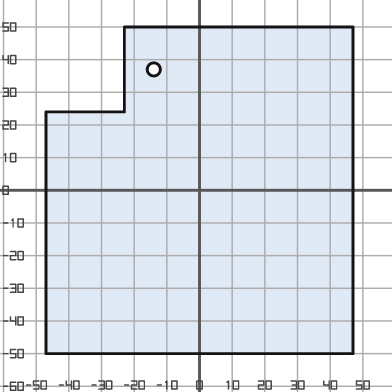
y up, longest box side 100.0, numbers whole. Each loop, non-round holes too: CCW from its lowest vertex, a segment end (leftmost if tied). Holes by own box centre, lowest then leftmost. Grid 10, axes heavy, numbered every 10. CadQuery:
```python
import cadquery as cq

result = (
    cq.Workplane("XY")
    .moveTo(-47.0, -50.0)
    .lineTo(47.0, -50.0)
    .lineTo(47.0, 50.0)
    .lineTo(-23.0, 50.0)
    .lineTo(-23.0, 24.0)
    .lineTo(-47.0, 24.0)
    .close()
    .moveTo(-14.0, 37.0)
    .circle(2.0)
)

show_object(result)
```